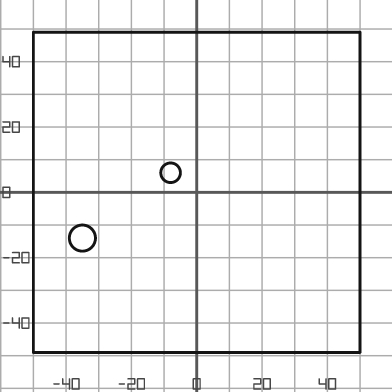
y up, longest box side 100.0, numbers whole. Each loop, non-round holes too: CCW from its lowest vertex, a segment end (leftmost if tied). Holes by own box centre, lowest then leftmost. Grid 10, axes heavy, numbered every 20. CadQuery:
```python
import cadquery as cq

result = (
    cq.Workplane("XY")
    .moveTo(-50.0, -49.0)
    .lineTo(50.0, -49.0)
    .lineTo(50.0, 49.0)
    .lineTo(-50.0, 49.0)
    .close()
    .moveTo(-35.0, -14.0)
    .circle(4.0)
    .moveTo(-8.0, 6.0)
    .circle(3.0)
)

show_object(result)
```